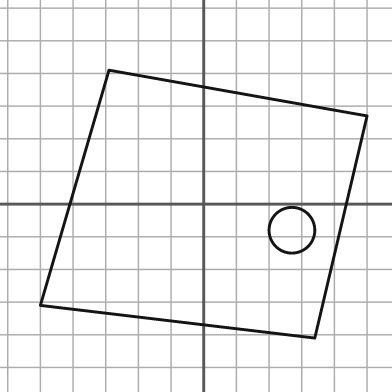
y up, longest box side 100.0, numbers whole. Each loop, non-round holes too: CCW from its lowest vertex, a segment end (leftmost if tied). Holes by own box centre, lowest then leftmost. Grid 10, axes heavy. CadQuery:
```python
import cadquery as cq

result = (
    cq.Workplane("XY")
    .moveTo(34.0, -41.0)
    .lineTo(50.0, 27.0)
    .lineTo(-29.0, 41.0)
    .lineTo(-50.0, -31.0)
    .close()
    .moveTo(27.0, -8.0)
    .circle(7.0)
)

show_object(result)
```